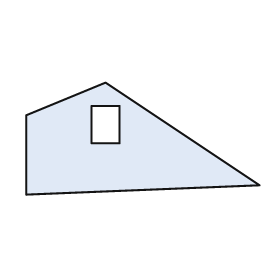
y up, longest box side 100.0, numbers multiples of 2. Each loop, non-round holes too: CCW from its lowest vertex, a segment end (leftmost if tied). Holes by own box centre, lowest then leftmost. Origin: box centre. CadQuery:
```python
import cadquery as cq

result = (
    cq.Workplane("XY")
    .moveTo(-50.0, -24.0)
    .lineTo(50.0, -20.0)
    .lineTo(-16.0, 24.0)
    .lineTo(-50.0, 10.0)
    .close()
    .moveTo(-22.0, -2.0)
    .lineTo(-10.0, -2.0)
    .lineTo(-10.0, 14.0)
    .lineTo(-22.0, 14.0)
    .close()
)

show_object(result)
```